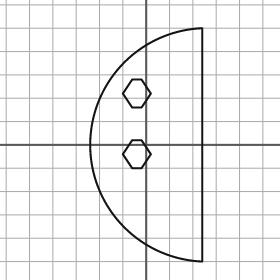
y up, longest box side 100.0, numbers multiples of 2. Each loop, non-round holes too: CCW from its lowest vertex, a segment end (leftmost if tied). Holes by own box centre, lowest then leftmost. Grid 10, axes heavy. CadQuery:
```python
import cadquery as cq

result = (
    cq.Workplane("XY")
    .moveTo(24.0, -50.0)
    .lineTo(24.0, 50.0)
    .threePointArc((-24.0, 0.0), (24.0, -50.0))
    .close()
    .moveTo(-6.0, -10.0)
    .lineTo(-2.0, -10.0)
    .lineTo(2.0, -4.0)
    .lineTo(-2.0, 2.0)
    .lineTo(-6.0, 2.0)
    .lineTo(-10.0, -4.0)
    .close()
    .moveTo(-6.0, 16.0)
    .lineTo(-2.0, 16.0)
    .lineTo(2.0, 22.0)
    .lineTo(-2.0, 28.0)
    .lineTo(-6.0, 28.0)
    .lineTo(-10.0, 22.0)
    .close()
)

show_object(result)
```